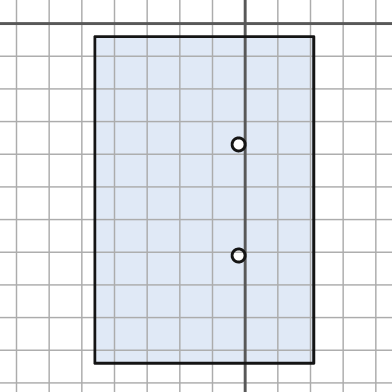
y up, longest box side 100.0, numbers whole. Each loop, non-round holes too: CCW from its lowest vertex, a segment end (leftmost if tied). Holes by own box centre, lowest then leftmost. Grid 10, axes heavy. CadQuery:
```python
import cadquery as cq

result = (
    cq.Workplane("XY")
    .moveTo(-46.0, -104.0)
    .lineTo(21.0, -104.0)
    .lineTo(21.0, -4.0)
    .lineTo(-46.0, -4.0)
    .close()
    .moveTo(-2.0, -71.0)
    .circle(2.0)
    .moveTo(-2.0, -37.0)
    .circle(2.0)
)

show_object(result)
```